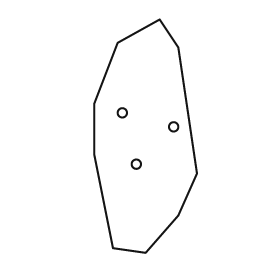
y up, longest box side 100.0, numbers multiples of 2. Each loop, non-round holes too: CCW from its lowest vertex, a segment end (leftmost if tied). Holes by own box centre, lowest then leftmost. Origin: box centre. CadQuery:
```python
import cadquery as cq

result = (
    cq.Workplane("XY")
    .moveTo(0.0, -50.0)
    .lineTo(14.0, -34.0)
    .lineTo(22.0, -16.0)
    .lineTo(14.0, 38.0)
    .lineTo(6.0, 50.0)
    .lineTo(-12.0, 40.0)
    .lineTo(-22.0, 14.0)
    .lineTo(-22.0, -8.0)
    .lineTo(-14.0, -48.0)
    .close()
    .moveTo(-4.0, -12.0)
    .circle(2.0)
    .moveTo(12.0, 4.0)
    .circle(2.0)
    .moveTo(-10.0, 10.0)
    .circle(2.0)
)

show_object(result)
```